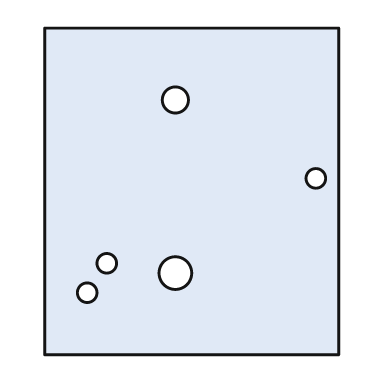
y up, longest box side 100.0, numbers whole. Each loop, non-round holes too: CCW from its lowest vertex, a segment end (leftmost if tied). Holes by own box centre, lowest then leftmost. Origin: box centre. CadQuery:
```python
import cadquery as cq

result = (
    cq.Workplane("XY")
    .moveTo(-45.0, -50.0)
    .lineTo(45.0, -50.0)
    .lineTo(45.0, 50.0)
    .lineTo(-45.0, 50.0)
    .close()
    .moveTo(-32.0, -31.0)
    .circle(3.0)
    .moveTo(-5.0, -25.0)
    .circle(5.0)
    .moveTo(-26.0, -22.0)
    .circle(3.0)
    .moveTo(38.0, 4.0)
    .circle(3.0)
    .moveTo(-5.0, 28.0)
    .circle(4.0)
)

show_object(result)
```